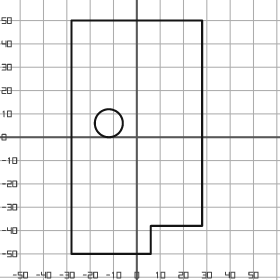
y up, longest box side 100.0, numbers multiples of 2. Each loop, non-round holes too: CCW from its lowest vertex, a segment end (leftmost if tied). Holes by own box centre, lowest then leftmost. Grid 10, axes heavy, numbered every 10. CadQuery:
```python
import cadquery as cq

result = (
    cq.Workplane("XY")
    .moveTo(-28.0, -50.0)
    .lineTo(6.0, -50.0)
    .lineTo(6.0, -38.0)
    .lineTo(28.0, -38.0)
    .lineTo(28.0, 50.0)
    .lineTo(-28.0, 50.0)
    .close()
    .moveTo(-12.0, 6.0)
    .circle(6.0)
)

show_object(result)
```